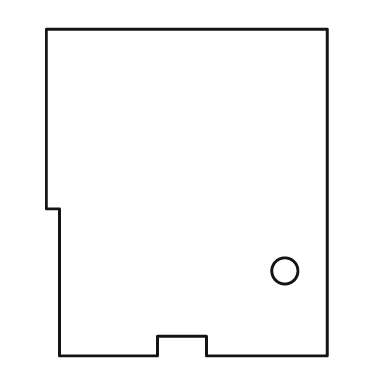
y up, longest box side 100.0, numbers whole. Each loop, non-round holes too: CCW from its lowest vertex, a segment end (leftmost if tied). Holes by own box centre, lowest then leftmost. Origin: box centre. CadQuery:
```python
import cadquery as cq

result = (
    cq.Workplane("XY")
    .moveTo(-39.0, -50.0)
    .lineTo(-9.0, -50.0)
    .lineTo(-9.0, -44.0)
    .lineTo(6.0, -44.0)
    .lineTo(6.0, -50.0)
    .lineTo(43.0, -50.0)
    .lineTo(43.0, 50.0)
    .lineTo(-43.0, 50.0)
    .lineTo(-43.0, -5.0)
    .lineTo(-39.0, -5.0)
    .close()
    .moveTo(30.0, -24.0)
    .circle(4.0)
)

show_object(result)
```